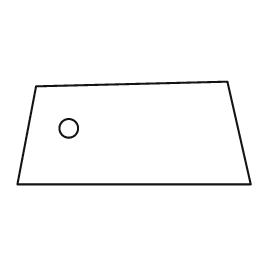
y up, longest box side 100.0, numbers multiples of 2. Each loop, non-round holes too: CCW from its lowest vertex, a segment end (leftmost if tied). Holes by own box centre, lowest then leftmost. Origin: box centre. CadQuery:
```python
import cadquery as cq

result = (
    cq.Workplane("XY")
    .moveTo(-50.0, -22.0)
    .lineTo(50.0, -22.0)
    .lineTo(40.0, 22.0)
    .lineTo(-42.0, 20.0)
    .close()
    .moveTo(-28.0, 2.0)
    .circle(4.0)
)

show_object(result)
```